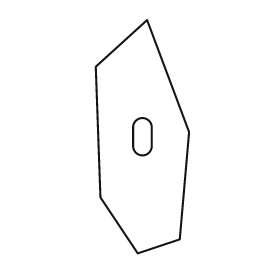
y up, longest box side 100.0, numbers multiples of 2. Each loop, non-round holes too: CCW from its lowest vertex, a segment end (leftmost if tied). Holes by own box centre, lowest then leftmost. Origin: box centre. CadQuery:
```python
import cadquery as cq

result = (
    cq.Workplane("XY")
    .moveTo(-2.0, -50.0)
    .lineTo(16.0, -44.0)
    .lineTo(20.0, 2.0)
    .lineTo(2.0, 50.0)
    .lineTo(-20.0, 30.0)
    .lineTo(-18.0, -26.0)
    .close()
    .moveTo(-4.0, -4.0)
    .threePointArc((0.0, -8.0), (4.0, -4.0))
    .lineTo(4.0, 4.0)
    .threePointArc((0.0, 8.0), (-4.0, 4.0))
    .close()
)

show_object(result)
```